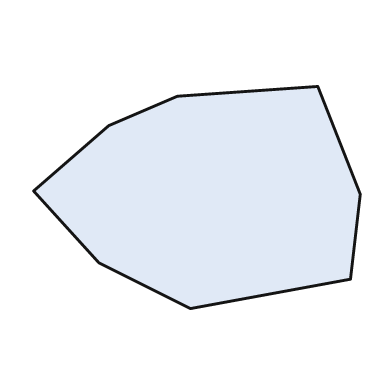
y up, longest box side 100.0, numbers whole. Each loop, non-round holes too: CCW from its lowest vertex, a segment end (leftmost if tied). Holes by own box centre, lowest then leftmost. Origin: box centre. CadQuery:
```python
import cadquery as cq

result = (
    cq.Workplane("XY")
    .moveTo(-2.0, -34.0)
    .lineTo(47.0, -25.0)
    .lineTo(50.0, 1.0)
    .lineTo(37.0, 34.0)
    .lineTo(-6.0, 31.0)
    .lineTo(-27.0, 22.0)
    .lineTo(-50.0, 2.0)
    .lineTo(-30.0, -20.0)
    .close()
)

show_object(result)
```